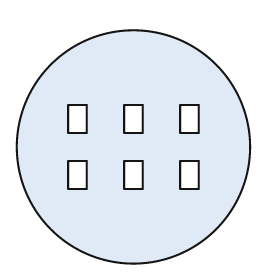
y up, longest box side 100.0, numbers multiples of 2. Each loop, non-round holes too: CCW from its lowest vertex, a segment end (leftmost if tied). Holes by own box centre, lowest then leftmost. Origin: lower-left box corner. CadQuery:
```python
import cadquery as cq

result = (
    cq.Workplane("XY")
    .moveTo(50.0, 50.0)
    .circle(50.0)
    .moveTo(22.0, 32.0)
    .lineTo(30.0, 32.0)
    .lineTo(30.0, 44.0)
    .lineTo(22.0, 44.0)
    .close()
    .moveTo(46.0, 32.0)
    .lineTo(54.0, 32.0)
    .lineTo(54.0, 44.0)
    .lineTo(46.0, 44.0)
    .close()
    .moveTo(70.0, 32.0)
    .lineTo(78.0, 32.0)
    .lineTo(78.0, 44.0)
    .lineTo(70.0, 44.0)
    .close()
    .moveTo(22.0, 56.0)
    .lineTo(30.0, 56.0)
    .lineTo(30.0, 68.0)
    .lineTo(22.0, 68.0)
    .close()
    .moveTo(46.0, 56.0)
    .lineTo(54.0, 56.0)
    .lineTo(54.0, 68.0)
    .lineTo(46.0, 68.0)
    .close()
    .moveTo(70.0, 56.0)
    .lineTo(78.0, 56.0)
    .lineTo(78.0, 68.0)
    .lineTo(70.0, 68.0)
    .close()
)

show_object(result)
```